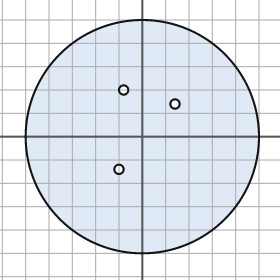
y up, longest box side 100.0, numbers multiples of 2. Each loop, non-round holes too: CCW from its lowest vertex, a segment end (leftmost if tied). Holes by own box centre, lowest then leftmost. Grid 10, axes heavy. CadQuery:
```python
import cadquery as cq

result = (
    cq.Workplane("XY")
    .moveTo(0.0, 0.0)
    .circle(50.0)
    .moveTo(-10.0, -14.0)
    .circle(2.0)
    .moveTo(14.0, 14.0)
    .circle(2.0)
    .moveTo(-8.0, 20.0)
    .circle(2.0)
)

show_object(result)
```